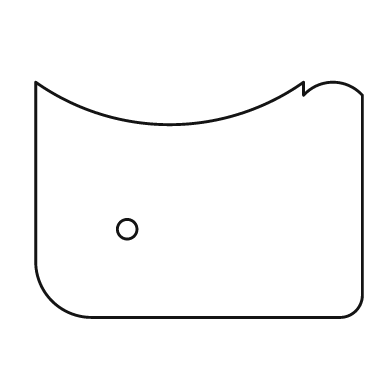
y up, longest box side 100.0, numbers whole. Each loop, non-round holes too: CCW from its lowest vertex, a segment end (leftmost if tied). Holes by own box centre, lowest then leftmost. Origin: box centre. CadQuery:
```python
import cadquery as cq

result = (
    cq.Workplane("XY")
    .moveTo(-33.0, -36.0)
    .lineTo(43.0, -36.0)
    .threePointArc((48.0, -34.0), (50.0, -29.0))
    .lineTo(50.0, 32.0)
    .threePointArc((41.0, 36.0), (32.0, 32.0))
    .lineTo(32.0, 36.0)
    .threePointArc((-9.0, 23.0), (-50.0, 36.0))
    .lineTo(-50.0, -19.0)
    .threePointArc((-45.0, -31.0), (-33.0, -36.0))
    .close()
    .moveTo(-22.0, -9.0)
    .circle(3.0)
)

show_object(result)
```